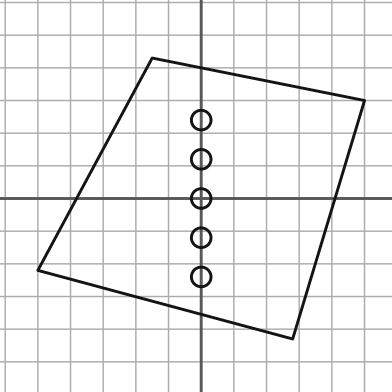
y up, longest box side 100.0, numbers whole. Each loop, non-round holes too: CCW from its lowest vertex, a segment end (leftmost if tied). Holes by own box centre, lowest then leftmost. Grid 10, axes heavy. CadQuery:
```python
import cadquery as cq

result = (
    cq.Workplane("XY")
    .moveTo(28.0, -43.0)
    .lineTo(50.0, 30.0)
    .lineTo(-15.0, 43.0)
    .lineTo(-50.0, -22.0)
    .close()
    .moveTo(0.0, -24.0)
    .circle(3.0)
    .moveTo(0.0, -12.0)
    .circle(3.0)
    .moveTo(0.0, 0.0)
    .circle(3.0)
    .moveTo(0.0, 12.0)
    .circle(3.0)
    .moveTo(0.0, 24.0)
    .circle(3.0)
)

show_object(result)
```